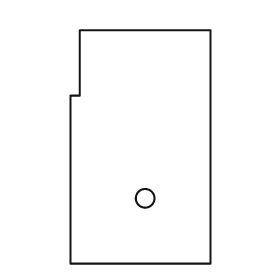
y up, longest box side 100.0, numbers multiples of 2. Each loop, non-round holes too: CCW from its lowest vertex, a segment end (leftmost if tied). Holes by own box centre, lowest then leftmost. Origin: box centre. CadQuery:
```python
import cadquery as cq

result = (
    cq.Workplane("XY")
    .moveTo(-30.0, -50.0)
    .lineTo(30.0, -50.0)
    .lineTo(30.0, 50.0)
    .lineTo(-26.0, 50.0)
    .lineTo(-26.0, 22.0)
    .lineTo(-30.0, 22.0)
    .close()
    .moveTo(2.0, -22.0)
    .circle(4.0)
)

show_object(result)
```